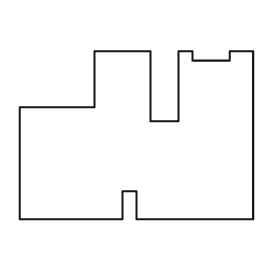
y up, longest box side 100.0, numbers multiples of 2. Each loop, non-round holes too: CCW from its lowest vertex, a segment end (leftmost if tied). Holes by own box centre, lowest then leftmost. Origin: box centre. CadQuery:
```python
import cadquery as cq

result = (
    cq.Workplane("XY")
    .moveTo(-50.0, -36.0)
    .lineTo(-6.0, -36.0)
    .lineTo(-6.0, -24.0)
    .lineTo(0.0, -24.0)
    .lineTo(0.0, -36.0)
    .lineTo(50.0, -36.0)
    .lineTo(50.0, 36.0)
    .lineTo(40.0, 36.0)
    .lineTo(40.0, 32.0)
    .lineTo(24.0, 32.0)
    .lineTo(24.0, 36.0)
    .lineTo(18.0, 36.0)
    .lineTo(18.0, 6.0)
    .lineTo(6.0, 6.0)
    .lineTo(6.0, 36.0)
    .lineTo(-18.0, 36.0)
    .lineTo(-18.0, 12.0)
    .lineTo(-50.0, 12.0)
    .close()
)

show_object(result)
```